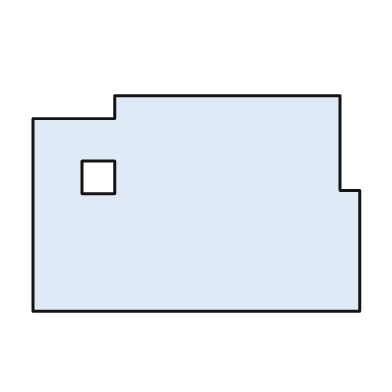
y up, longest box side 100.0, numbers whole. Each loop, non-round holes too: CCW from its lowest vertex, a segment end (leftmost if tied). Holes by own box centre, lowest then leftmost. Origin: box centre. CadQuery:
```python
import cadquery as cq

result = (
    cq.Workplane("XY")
    .moveTo(-50.0, -33.0)
    .lineTo(50.0, -33.0)
    .lineTo(50.0, 4.0)
    .lineTo(44.0, 4.0)
    .lineTo(44.0, 33.0)
    .lineTo(-25.0, 33.0)
    .lineTo(-25.0, 26.0)
    .lineTo(-50.0, 26.0)
    .close()
    .moveTo(-35.0, 3.0)
    .lineTo(-25.0, 3.0)
    .lineTo(-25.0, 13.0)
    .lineTo(-35.0, 13.0)
    .close()
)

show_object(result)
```